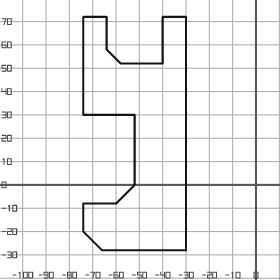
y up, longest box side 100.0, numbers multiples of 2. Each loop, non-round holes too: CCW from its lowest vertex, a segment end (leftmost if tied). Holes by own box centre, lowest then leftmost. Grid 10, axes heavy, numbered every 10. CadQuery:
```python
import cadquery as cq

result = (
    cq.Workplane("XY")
    .moveTo(-66.0, -28.0)
    .lineTo(-30.0, -28.0)
    .lineTo(-30.0, 72.0)
    .lineTo(-40.0, 72.0)
    .lineTo(-40.0, 52.0)
    .lineTo(-58.0, 52.0)
    .lineTo(-64.0, 58.0)
    .lineTo(-64.0, 72.0)
    .lineTo(-74.0, 72.0)
    .lineTo(-74.0, 30.0)
    .lineTo(-52.0, 30.0)
    .lineTo(-52.0, 0.0)
    .lineTo(-60.0, -8.0)
    .lineTo(-74.0, -8.0)
    .lineTo(-74.0, -20.0)
    .close()
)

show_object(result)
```